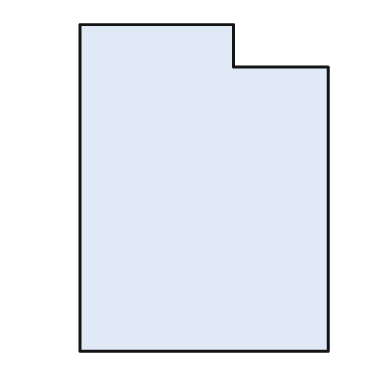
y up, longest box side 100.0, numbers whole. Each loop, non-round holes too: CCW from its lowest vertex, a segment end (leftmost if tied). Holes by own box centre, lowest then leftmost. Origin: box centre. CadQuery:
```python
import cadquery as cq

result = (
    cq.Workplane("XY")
    .moveTo(-38.0, -50.0)
    .lineTo(38.0, -50.0)
    .lineTo(38.0, 37.0)
    .lineTo(9.0, 37.0)
    .lineTo(9.0, 50.0)
    .lineTo(-38.0, 50.0)
    .close()
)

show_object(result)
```